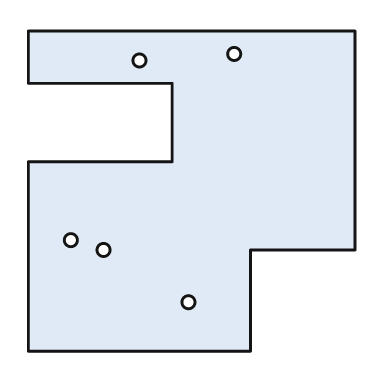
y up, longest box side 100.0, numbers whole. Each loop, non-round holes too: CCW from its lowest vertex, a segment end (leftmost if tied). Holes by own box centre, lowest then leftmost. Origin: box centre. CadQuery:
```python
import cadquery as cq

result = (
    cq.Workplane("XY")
    .moveTo(-50.0, -49.0)
    .lineTo(18.0, -49.0)
    .lineTo(18.0, -18.0)
    .lineTo(50.0, -18.0)
    .lineTo(50.0, 49.0)
    .lineTo(-50.0, 49.0)
    .lineTo(-50.0, 33.0)
    .lineTo(-6.0, 33.0)
    .lineTo(-6.0, 9.0)
    .lineTo(-50.0, 9.0)
    .close()
    .moveTo(-1.0, -34.0)
    .circle(2.0)
    .moveTo(-27.0, -18.0)
    .circle(2.0)
    .moveTo(-37.0, -15.0)
    .circle(2.0)
    .moveTo(-16.0, 40.0)
    .circle(2.0)
    .moveTo(13.0, 42.0)
    .circle(2.0)
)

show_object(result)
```